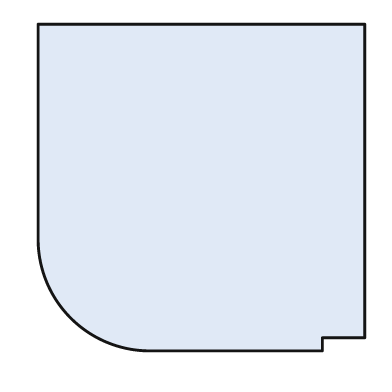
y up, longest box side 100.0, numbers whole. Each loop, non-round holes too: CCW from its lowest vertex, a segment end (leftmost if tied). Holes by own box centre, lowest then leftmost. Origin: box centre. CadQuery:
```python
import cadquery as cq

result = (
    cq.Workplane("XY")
    .moveTo(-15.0, -50.0)
    .lineTo(37.0, -50.0)
    .lineTo(37.0, -46.0)
    .lineTo(50.0, -46.0)
    .lineTo(50.0, 50.0)
    .lineTo(-50.0, 50.0)
    .lineTo(-50.0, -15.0)
    .threePointArc((-40.0, -40.0), (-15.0, -50.0))
    .close()
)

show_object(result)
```